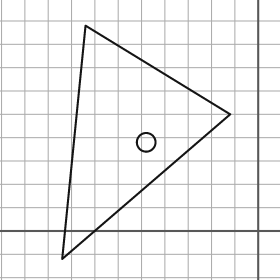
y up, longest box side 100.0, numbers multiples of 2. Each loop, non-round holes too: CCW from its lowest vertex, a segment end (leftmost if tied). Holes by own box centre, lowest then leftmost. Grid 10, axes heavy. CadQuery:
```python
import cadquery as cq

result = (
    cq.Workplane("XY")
    .moveTo(-84.0, -12.0)
    .lineTo(-12.0, 50.0)
    .lineTo(-74.0, 88.0)
    .close()
    .moveTo(-48.0, 38.0)
    .circle(4.0)
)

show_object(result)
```